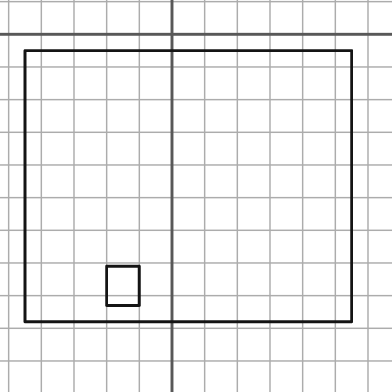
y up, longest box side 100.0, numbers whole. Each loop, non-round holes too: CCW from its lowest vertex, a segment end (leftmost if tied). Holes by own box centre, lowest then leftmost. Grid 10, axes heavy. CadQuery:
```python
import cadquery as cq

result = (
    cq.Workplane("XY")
    .moveTo(-45.0, -88.0)
    .lineTo(55.0, -88.0)
    .lineTo(55.0, -5.0)
    .lineTo(-45.0, -5.0)
    .close()
    .moveTo(-20.0, -83.0)
    .lineTo(-10.0, -83.0)
    .lineTo(-10.0, -71.0)
    .lineTo(-20.0, -71.0)
    .close()
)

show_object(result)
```